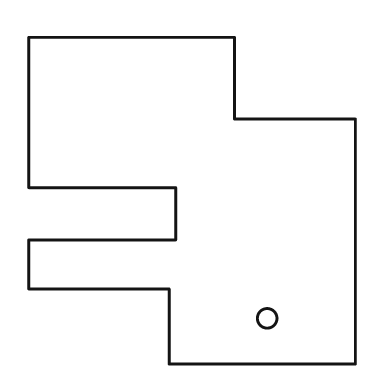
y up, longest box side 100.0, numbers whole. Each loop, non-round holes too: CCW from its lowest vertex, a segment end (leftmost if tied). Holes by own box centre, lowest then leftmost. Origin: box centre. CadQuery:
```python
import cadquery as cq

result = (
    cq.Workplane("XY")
    .moveTo(-7.0, -50.0)
    .lineTo(50.0, -50.0)
    .lineTo(50.0, 25.0)
    .lineTo(13.0, 25.0)
    .lineTo(13.0, 50.0)
    .lineTo(-50.0, 50.0)
    .lineTo(-50.0, 4.0)
    .lineTo(-5.0, 4.0)
    .lineTo(-5.0, -12.0)
    .lineTo(-50.0, -12.0)
    .lineTo(-50.0, -27.0)
    .lineTo(-7.0, -27.0)
    .close()
    .moveTo(23.0, -36.0)
    .circle(3.0)
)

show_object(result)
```